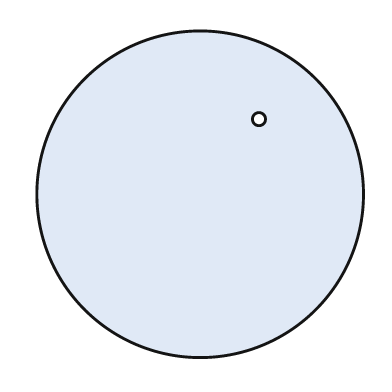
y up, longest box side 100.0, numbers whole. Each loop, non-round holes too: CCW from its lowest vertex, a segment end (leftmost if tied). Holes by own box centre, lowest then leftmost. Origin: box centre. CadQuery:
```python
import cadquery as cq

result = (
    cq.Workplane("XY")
    .moveTo(0.0, 0.0)
    .circle(50.0)
    .moveTo(18.0, 23.0)
    .circle(2.0)
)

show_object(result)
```